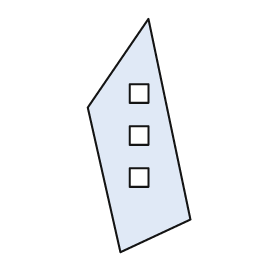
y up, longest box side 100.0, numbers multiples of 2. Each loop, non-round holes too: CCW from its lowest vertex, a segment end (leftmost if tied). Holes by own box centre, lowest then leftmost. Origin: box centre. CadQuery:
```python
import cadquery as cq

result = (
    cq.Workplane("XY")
    .moveTo(-8.0, -50.0)
    .lineTo(22.0, -36.0)
    .lineTo(4.0, 50.0)
    .lineTo(-22.0, 12.0)
    .close()
    .moveTo(-4.0, -22.0)
    .lineTo(4.0, -22.0)
    .lineTo(4.0, -14.0)
    .lineTo(-4.0, -14.0)
    .close()
    .moveTo(-4.0, -4.0)
    .lineTo(4.0, -4.0)
    .lineTo(4.0, 4.0)
    .lineTo(-4.0, 4.0)
    .close()
    .moveTo(-4.0, 14.0)
    .lineTo(4.0, 14.0)
    .lineTo(4.0, 22.0)
    .lineTo(-4.0, 22.0)
    .close()
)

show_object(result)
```